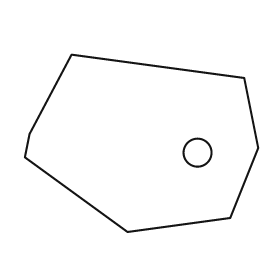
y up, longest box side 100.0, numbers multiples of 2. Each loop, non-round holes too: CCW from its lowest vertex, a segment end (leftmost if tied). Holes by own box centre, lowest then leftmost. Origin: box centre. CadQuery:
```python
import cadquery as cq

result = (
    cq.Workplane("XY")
    .moveTo(-6.0, -38.0)
    .lineTo(38.0, -32.0)
    .lineTo(50.0, -2.0)
    .lineTo(44.0, 28.0)
    .lineTo(-30.0, 38.0)
    .lineTo(-48.0, 4.0)
    .lineTo(-50.0, -6.0)
    .close()
    .moveTo(24.0, -4.0)
    .circle(6.0)
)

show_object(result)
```